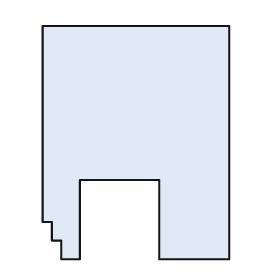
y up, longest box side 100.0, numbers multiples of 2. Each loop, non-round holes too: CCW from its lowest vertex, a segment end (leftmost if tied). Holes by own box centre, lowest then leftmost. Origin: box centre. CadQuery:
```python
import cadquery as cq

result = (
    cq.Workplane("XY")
    .moveTo(-32.0, -50.0)
    .lineTo(-24.0, -50.0)
    .lineTo(-24.0, -16.0)
    .lineTo(10.0, -16.0)
    .lineTo(10.0, -50.0)
    .lineTo(40.0, -50.0)
    .lineTo(40.0, 50.0)
    .lineTo(-40.0, 50.0)
    .lineTo(-40.0, -34.0)
    .lineTo(-36.0, -34.0)
    .lineTo(-36.0, -42.0)
    .lineTo(-32.0, -42.0)
    .close()
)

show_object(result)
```